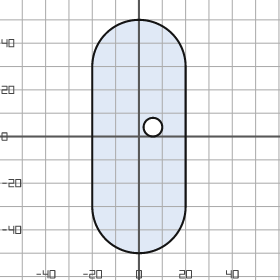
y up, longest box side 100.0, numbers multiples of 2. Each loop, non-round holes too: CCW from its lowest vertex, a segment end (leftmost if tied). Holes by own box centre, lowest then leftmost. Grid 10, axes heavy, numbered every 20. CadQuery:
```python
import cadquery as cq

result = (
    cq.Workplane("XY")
    .moveTo(-20.0, -30.0)
    .threePointArc((0.0, -50.0), (20.0, -30.0))
    .lineTo(20.0, 30.0)
    .threePointArc((0.0, 50.0), (-20.0, 30.0))
    .close()
    .moveTo(6.0, 4.0)
    .circle(4.0)
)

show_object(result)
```